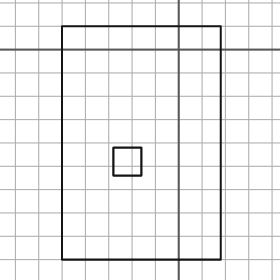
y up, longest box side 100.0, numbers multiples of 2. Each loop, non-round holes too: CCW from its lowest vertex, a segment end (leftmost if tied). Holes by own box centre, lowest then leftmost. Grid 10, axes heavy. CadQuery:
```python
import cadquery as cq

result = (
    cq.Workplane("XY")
    .moveTo(-50.0, -90.0)
    .lineTo(18.0, -90.0)
    .lineTo(18.0, 10.0)
    .lineTo(-50.0, 10.0)
    .close()
    .moveTo(-28.0, -54.0)
    .lineTo(-16.0, -54.0)
    .lineTo(-16.0, -42.0)
    .lineTo(-28.0, -42.0)
    .close()
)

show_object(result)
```